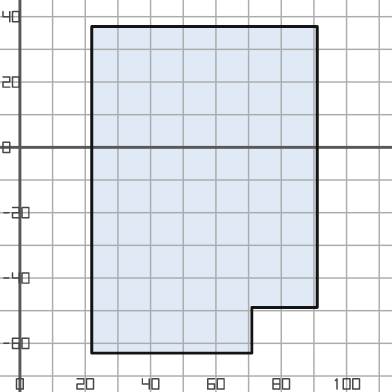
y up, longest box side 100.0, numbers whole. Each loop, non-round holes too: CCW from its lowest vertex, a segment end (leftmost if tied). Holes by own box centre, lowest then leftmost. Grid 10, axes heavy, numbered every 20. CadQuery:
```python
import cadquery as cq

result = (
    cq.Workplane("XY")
    .moveTo(22.0, -63.0)
    .lineTo(71.0, -63.0)
    .lineTo(71.0, -49.0)
    .lineTo(91.0, -49.0)
    .lineTo(91.0, 37.0)
    .lineTo(22.0, 37.0)
    .close()
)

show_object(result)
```